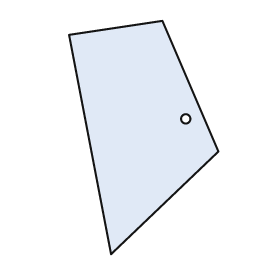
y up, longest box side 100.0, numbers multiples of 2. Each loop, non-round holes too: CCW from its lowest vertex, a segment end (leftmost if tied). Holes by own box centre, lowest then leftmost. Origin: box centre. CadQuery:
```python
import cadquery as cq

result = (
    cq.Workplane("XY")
    .moveTo(-14.0, -50.0)
    .lineTo(32.0, -6.0)
    .lineTo(8.0, 50.0)
    .lineTo(-32.0, 44.0)
    .close()
    .moveTo(18.0, 8.0)
    .circle(2.0)
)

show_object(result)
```